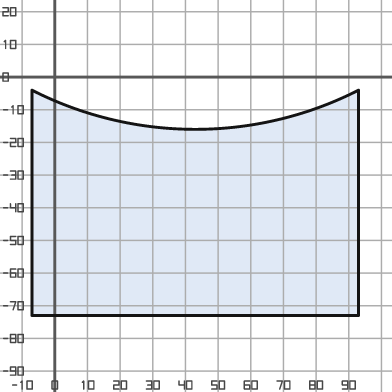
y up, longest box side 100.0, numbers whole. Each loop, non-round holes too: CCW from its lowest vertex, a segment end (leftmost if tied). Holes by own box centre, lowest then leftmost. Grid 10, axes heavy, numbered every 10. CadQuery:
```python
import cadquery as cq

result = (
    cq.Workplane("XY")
    .moveTo(-7.0, -73.0)
    .lineTo(93.0, -73.0)
    .lineTo(93.0, -4.0)
    .threePointArc((43.0, -16.0), (-7.0, -4.0))
    .close()
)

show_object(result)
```